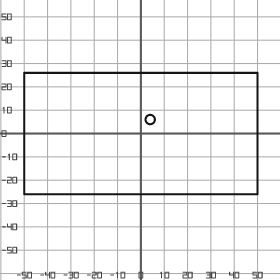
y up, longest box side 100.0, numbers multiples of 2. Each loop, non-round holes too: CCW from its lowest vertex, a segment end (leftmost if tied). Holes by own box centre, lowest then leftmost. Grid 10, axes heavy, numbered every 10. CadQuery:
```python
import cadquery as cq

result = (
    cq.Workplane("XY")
    .moveTo(-50.0, -26.0)
    .lineTo(50.0, -26.0)
    .lineTo(50.0, 26.0)
    .lineTo(-50.0, 26.0)
    .close()
    .moveTo(4.0, 6.0)
    .circle(2.0)
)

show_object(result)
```